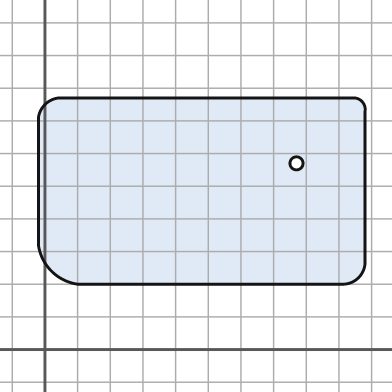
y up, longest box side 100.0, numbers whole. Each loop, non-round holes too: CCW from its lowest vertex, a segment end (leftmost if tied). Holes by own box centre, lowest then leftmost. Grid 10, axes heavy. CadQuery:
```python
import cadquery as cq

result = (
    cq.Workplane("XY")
    .moveTo(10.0, 20.0)
    .lineTo(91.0, 20.0)
    .threePointArc((96.0, 22.0), (98.0, 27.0))
    .lineTo(98.0, 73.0)
    .threePointArc((97.0, 76.0), (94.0, 77.0))
    .lineTo(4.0, 77.0)
    .threePointArc((0.0, 75.0), (-2.0, 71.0))
    .lineTo(-2.0, 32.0)
    .threePointArc((2.0, 24.0), (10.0, 20.0))
    .close()
    .moveTo(77.0, 57.0)
    .circle(2.0)
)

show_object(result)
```